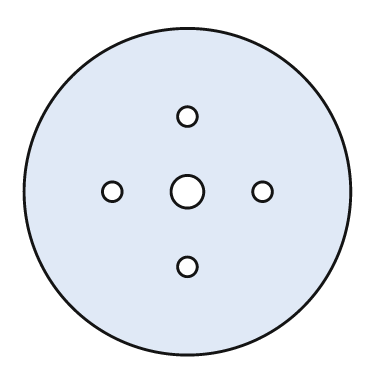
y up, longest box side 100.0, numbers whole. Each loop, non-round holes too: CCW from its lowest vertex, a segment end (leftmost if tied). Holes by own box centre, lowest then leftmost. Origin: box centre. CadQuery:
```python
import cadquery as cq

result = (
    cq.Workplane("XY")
    .moveTo(0.0, 0.0)
    .circle(50.0)
    .moveTo(0.0, -23.0)
    .circle(3.0)
    .moveTo(-23.0, 0.0)
    .circle(3.0)
    .moveTo(0.0, 0.0)
    .circle(5.0)
    .moveTo(23.0, 0.0)
    .circle(3.0)
    .moveTo(0.0, 23.0)
    .circle(3.0)
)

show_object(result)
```